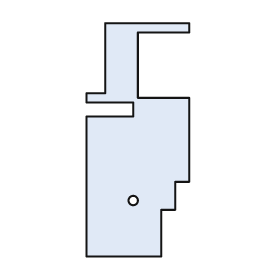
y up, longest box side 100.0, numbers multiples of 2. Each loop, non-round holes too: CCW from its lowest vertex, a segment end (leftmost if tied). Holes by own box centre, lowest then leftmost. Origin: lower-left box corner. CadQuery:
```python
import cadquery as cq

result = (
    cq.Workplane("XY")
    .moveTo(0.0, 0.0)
    .lineTo(32.0, 0.0)
    .lineTo(32.0, 20.0)
    .lineTo(38.0, 20.0)
    .lineTo(38.0, 32.0)
    .lineTo(44.0, 32.0)
    .lineTo(44.0, 68.0)
    .lineTo(22.0, 68.0)
    .lineTo(22.0, 96.0)
    .lineTo(44.0, 96.0)
    .lineTo(44.0, 100.0)
    .lineTo(8.0, 100.0)
    .lineTo(8.0, 70.0)
    .lineTo(0.0, 70.0)
    .lineTo(0.0, 66.0)
    .lineTo(20.0, 66.0)
    .lineTo(20.0, 60.0)
    .lineTo(0.0, 60.0)
    .close()
    .moveTo(20.0, 24.0)
    .circle(2.0)
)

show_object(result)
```